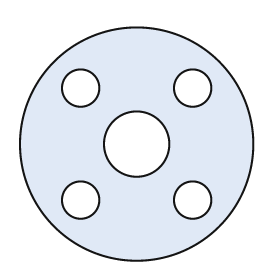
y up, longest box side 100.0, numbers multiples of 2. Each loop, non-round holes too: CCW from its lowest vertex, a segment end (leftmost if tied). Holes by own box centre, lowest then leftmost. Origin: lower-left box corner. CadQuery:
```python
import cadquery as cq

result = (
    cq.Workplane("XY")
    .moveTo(50.0, 50.0)
    .circle(50.0)
    .moveTo(26.0, 26.0)
    .circle(8.0)
    .moveTo(74.0, 26.0)
    .circle(8.0)
    .moveTo(50.0, 50.0)
    .circle(14.0)
    .moveTo(26.0, 74.0)
    .circle(8.0)
    .moveTo(74.0, 74.0)
    .circle(8.0)
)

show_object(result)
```